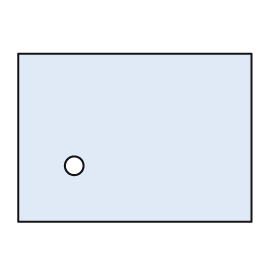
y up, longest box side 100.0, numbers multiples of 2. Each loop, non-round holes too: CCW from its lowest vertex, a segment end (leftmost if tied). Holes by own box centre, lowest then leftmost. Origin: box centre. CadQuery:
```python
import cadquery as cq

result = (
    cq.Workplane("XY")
    .moveTo(-50.0, -36.0)
    .lineTo(50.0, -36.0)
    .lineTo(50.0, 36.0)
    .lineTo(-50.0, 36.0)
    .close()
    .moveTo(-26.0, -12.0)
    .circle(4.0)
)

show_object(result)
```